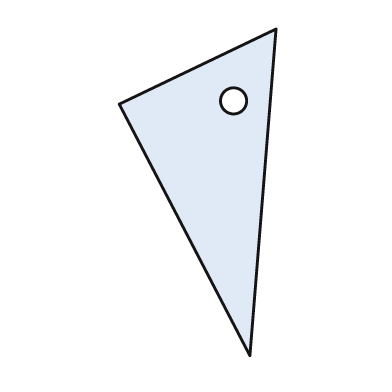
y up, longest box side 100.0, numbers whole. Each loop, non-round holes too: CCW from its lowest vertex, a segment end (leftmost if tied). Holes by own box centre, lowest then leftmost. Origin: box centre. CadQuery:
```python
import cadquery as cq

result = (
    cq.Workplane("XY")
    .moveTo(16.0, -50.0)
    .lineTo(24.0, 50.0)
    .lineTo(-24.0, 27.0)
    .close()
    .moveTo(11.0, 28.0)
    .circle(4.0)
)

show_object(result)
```